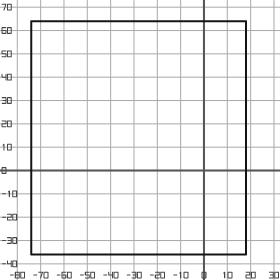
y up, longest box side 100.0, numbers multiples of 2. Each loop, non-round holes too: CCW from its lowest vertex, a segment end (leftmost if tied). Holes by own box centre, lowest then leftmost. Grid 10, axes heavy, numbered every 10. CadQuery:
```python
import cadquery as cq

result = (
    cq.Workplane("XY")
    .moveTo(-74.0, -36.0)
    .lineTo(18.0, -36.0)
    .lineTo(18.0, 64.0)
    .lineTo(-74.0, 64.0)
    .close()
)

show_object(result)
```